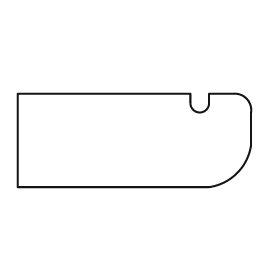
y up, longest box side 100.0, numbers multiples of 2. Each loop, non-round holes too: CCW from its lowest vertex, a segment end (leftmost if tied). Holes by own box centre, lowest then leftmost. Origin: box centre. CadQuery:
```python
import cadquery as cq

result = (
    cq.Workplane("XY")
    .moveTo(-50.0, -20.0)
    .lineTo(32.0, -20.0)
    .threePointArc((44.0, -14.0), (50.0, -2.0))
    .lineTo(50.0, 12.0)
    .threePointArc((48.0, 18.0), (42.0, 20.0))
    .lineTo(32.0, 20.0)
    .lineTo(32.0, 16.0)
    .threePointArc((28.0, 12.0), (24.0, 16.0))
    .lineTo(24.0, 20.0)
    .lineTo(-50.0, 20.0)
    .close()
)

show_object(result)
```